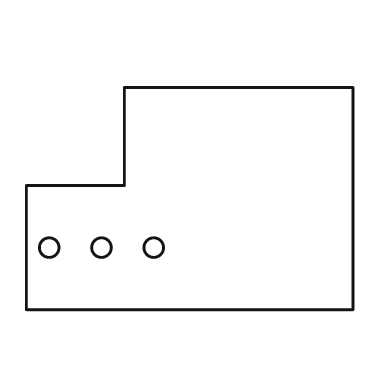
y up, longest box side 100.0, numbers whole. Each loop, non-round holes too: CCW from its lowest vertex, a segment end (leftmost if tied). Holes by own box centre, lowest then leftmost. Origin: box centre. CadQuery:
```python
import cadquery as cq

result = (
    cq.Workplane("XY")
    .moveTo(-50.0, -34.0)
    .lineTo(50.0, -34.0)
    .lineTo(50.0, 34.0)
    .lineTo(-20.0, 34.0)
    .lineTo(-20.0, 4.0)
    .lineTo(-50.0, 4.0)
    .close()
    .moveTo(-43.0, -15.0)
    .circle(3.0)
    .moveTo(-27.0, -15.0)
    .circle(3.0)
    .moveTo(-11.0, -15.0)
    .circle(3.0)
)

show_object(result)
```